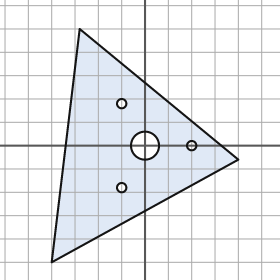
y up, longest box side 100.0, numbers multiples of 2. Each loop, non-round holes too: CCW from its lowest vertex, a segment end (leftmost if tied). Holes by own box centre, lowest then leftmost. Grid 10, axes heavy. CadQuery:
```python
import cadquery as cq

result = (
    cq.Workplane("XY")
    .moveTo(-40.0, -50.0)
    .lineTo(40.0, -6.0)
    .lineTo(-28.0, 50.0)
    .close()
    .moveTo(-10.0, -18.0)
    .circle(2.0)
    .moveTo(0.0, 0.0)
    .circle(6.0)
    .moveTo(20.0, 0.0)
    .circle(2.0)
    .moveTo(-10.0, 18.0)
    .circle(2.0)
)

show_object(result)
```